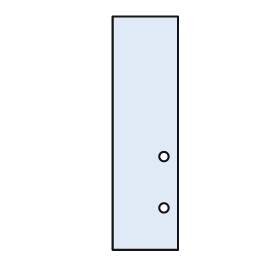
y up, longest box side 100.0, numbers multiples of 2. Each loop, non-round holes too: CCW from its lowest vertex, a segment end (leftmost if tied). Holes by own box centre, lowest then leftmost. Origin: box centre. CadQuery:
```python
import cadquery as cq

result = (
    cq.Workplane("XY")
    .moveTo(-14.0, -50.0)
    .lineTo(14.0, -50.0)
    .lineTo(14.0, 50.0)
    .lineTo(-14.0, 50.0)
    .close()
    .moveTo(8.0, -32.0)
    .circle(2.0)
    .moveTo(8.0, -10.0)
    .circle(2.0)
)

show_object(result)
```